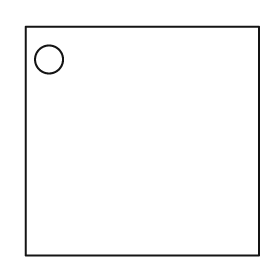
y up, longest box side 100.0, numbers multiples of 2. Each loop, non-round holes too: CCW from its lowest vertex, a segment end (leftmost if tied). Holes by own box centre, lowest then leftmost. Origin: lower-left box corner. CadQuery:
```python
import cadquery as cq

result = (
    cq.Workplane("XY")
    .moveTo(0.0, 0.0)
    .lineTo(100.0, 0.0)
    .lineTo(100.0, 98.0)
    .lineTo(0.0, 98.0)
    .close()
    .moveTo(10.0, 84.0)
    .circle(6.0)
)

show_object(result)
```